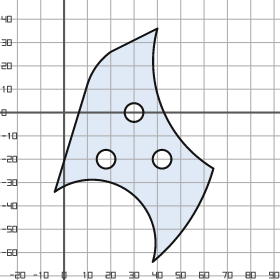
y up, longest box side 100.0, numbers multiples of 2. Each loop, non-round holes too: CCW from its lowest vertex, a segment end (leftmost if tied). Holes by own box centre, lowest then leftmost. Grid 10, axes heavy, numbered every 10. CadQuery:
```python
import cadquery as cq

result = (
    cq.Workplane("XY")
    .moveTo(38.0, -64.0)
    .threePointArc((54.0, -46.0), (64.0, -24.0))
    .threePointArc((42.0, 2.0), (40.0, 36.0))
    .lineTo(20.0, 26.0)
    .threePointArc((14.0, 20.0), (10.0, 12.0))
    .lineTo(-4.0, -34.0)
    .threePointArc((28.0, -34.0), (38.0, -64.0))
    .close()
    .moveTo(18.0, -20.0)
    .circle(4.0)
    .moveTo(42.0, -20.0)
    .circle(4.0)
    .moveTo(30.0, 0.0)
    .circle(4.0)
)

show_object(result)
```